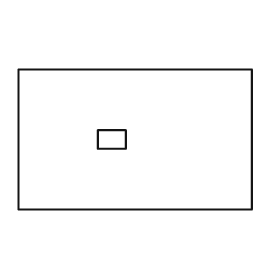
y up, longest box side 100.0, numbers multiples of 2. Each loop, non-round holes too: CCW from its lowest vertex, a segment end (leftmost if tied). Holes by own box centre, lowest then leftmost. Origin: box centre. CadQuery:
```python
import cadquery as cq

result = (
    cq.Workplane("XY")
    .moveTo(-50.0, -30.0)
    .lineTo(50.0, -30.0)
    .lineTo(50.0, 30.0)
    .lineTo(-50.0, 30.0)
    .close()
    .moveTo(-16.0, -4.0)
    .lineTo(-4.0, -4.0)
    .lineTo(-4.0, 4.0)
    .lineTo(-16.0, 4.0)
    .close()
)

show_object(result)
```